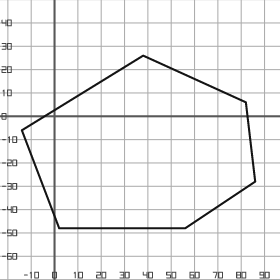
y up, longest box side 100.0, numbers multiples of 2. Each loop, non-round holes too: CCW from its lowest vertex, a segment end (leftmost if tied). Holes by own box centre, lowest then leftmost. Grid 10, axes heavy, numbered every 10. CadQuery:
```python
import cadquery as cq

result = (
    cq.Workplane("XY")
    .moveTo(2.0, -48.0)
    .lineTo(56.0, -48.0)
    .lineTo(86.0, -28.0)
    .lineTo(82.0, 6.0)
    .lineTo(38.0, 26.0)
    .lineTo(-14.0, -6.0)
    .close()
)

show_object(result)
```